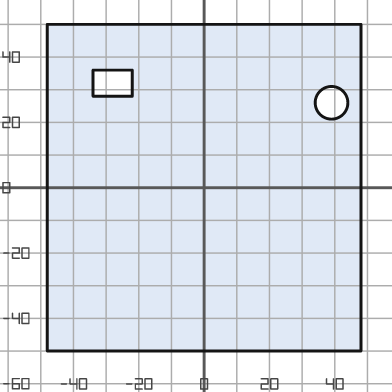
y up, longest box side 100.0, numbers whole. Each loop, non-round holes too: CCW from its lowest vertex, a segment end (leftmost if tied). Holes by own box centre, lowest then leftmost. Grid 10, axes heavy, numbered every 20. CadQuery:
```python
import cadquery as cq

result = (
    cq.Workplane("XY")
    .moveTo(-48.0, -50.0)
    .lineTo(48.0, -50.0)
    .lineTo(48.0, 50.0)
    .lineTo(-48.0, 50.0)
    .close()
    .moveTo(39.0, 26.0)
    .circle(5.0)
    .moveTo(-34.0, 28.0)
    .lineTo(-22.0, 28.0)
    .lineTo(-22.0, 36.0)
    .lineTo(-34.0, 36.0)
    .close()
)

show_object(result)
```